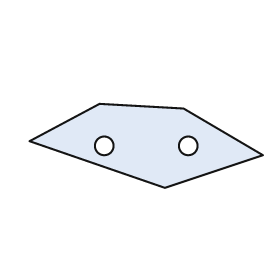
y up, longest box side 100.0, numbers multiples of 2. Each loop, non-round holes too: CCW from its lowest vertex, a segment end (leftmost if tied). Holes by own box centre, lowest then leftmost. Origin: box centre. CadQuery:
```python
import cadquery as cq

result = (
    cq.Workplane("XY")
    .moveTo(8.0, -18.0)
    .lineTo(50.0, -4.0)
    .lineTo(16.0, 16.0)
    .lineTo(-20.0, 18.0)
    .lineTo(-50.0, 2.0)
    .close()
    .moveTo(-18.0, 0.0)
    .circle(4.0)
    .moveTo(18.0, 0.0)
    .circle(4.0)
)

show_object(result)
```